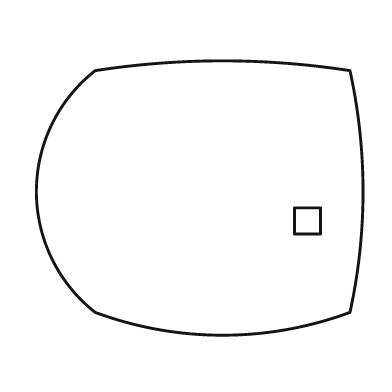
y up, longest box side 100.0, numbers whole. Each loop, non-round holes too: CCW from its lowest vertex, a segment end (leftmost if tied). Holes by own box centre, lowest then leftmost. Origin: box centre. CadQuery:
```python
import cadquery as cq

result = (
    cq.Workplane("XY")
    .moveTo(-32.0, -35.0)
    .threePointArc((7.0, -42.0), (46.0, -35.0))
    .threePointArc((50.0, 2.0), (46.0, 39.0))
    .threePointArc((7.0, 42.0), (-32.0, 39.0))
    .threePointArc((-50.0, 2.0), (-32.0, -35.0))
    .close()
    .moveTo(29.0, -11.0)
    .lineTo(37.0, -11.0)
    .lineTo(37.0, -3.0)
    .lineTo(29.0, -3.0)
    .close()
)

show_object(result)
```